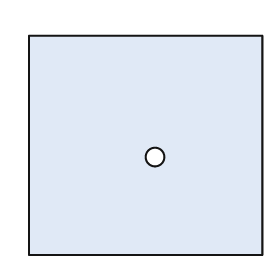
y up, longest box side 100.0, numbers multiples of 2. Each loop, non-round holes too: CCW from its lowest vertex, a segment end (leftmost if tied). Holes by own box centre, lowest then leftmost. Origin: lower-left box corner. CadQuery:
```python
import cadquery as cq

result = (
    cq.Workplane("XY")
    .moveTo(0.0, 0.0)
    .lineTo(100.0, 0.0)
    .lineTo(100.0, 94.0)
    .lineTo(0.0, 94.0)
    .close()
    .moveTo(54.0, 42.0)
    .circle(4.0)
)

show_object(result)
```